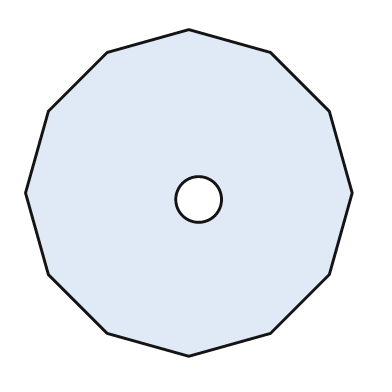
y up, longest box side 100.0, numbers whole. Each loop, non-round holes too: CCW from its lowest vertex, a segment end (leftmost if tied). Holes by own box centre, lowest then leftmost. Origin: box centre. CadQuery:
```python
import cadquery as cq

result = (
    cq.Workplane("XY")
    .moveTo(0.0, -50.0)
    .lineTo(25.0, -43.0)
    .lineTo(43.0, -25.0)
    .lineTo(50.0, 0.0)
    .lineTo(43.0, 25.0)
    .lineTo(25.0, 43.0)
    .lineTo(0.0, 50.0)
    .lineTo(-25.0, 43.0)
    .lineTo(-43.0, 25.0)
    .lineTo(-50.0, 0.0)
    .lineTo(-43.0, -25.0)
    .lineTo(-25.0, -43.0)
    .close()
    .moveTo(3.0, -2.0)
    .circle(7.0)
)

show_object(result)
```